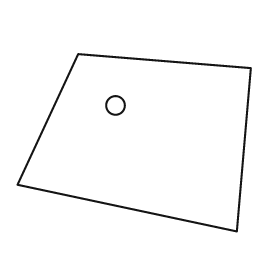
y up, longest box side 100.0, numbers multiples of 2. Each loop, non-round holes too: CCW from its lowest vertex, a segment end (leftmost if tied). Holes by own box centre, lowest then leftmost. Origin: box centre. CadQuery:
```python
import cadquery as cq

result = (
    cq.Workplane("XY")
    .moveTo(44.0, -38.0)
    .lineTo(50.0, 32.0)
    .lineTo(-24.0, 38.0)
    .lineTo(-50.0, -18.0)
    .close()
    .moveTo(-8.0, 16.0)
    .circle(4.0)
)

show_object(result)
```